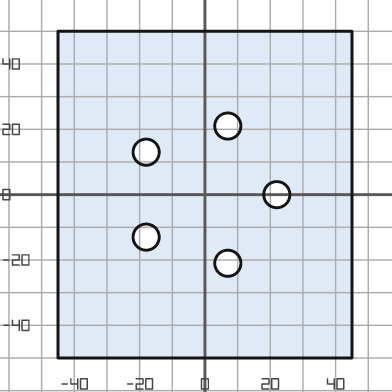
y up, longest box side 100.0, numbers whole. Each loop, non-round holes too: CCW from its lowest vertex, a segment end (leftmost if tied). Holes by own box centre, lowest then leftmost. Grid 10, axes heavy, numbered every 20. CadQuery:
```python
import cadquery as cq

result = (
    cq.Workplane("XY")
    .moveTo(-45.0, -50.0)
    .lineTo(45.0, -50.0)
    .lineTo(45.0, 50.0)
    .lineTo(-45.0, 50.0)
    .close()
    .moveTo(7.0, -21.0)
    .circle(4.0)
    .moveTo(-18.0, -13.0)
    .circle(4.0)
    .moveTo(22.0, 0.0)
    .circle(4.0)
    .moveTo(-18.0, 13.0)
    .circle(4.0)
    .moveTo(7.0, 21.0)
    .circle(4.0)
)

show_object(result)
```